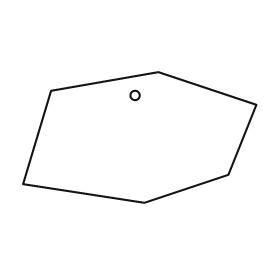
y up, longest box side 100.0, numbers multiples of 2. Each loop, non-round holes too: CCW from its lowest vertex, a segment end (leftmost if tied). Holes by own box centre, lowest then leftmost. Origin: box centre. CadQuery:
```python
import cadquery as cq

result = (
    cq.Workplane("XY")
    .moveTo(2.0, -28.0)
    .lineTo(38.0, -16.0)
    .lineTo(50.0, 14.0)
    .lineTo(8.0, 28.0)
    .lineTo(-38.0, 20.0)
    .lineTo(-50.0, -20.0)
    .close()
    .moveTo(-2.0, 18.0)
    .circle(2.0)
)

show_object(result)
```